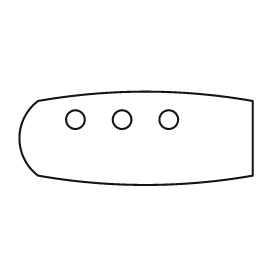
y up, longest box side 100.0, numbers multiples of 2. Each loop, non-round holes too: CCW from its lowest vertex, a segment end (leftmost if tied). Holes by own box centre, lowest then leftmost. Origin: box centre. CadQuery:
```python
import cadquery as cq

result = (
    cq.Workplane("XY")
    .moveTo(-42.0, -16.0)
    .threePointArc((4.0, -20.0), (50.0, -16.0))
    .lineTo(50.0, 16.0)
    .threePointArc((4.0, 20.0), (-42.0, 16.0))
    .threePointArc((-50.0, 0.0), (-42.0, -16.0))
    .close()
    .moveTo(-26.0, 8.0)
    .circle(4.0)
    .moveTo(-6.0, 8.0)
    .circle(4.0)
    .moveTo(14.0, 8.0)
    .circle(4.0)
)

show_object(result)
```